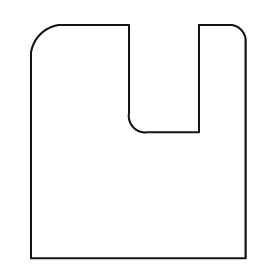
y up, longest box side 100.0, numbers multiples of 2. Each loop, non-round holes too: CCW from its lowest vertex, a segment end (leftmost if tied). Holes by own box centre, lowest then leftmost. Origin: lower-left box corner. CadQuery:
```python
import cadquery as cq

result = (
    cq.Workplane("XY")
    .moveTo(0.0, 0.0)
    .lineTo(92.0, 0.0)
    .lineTo(92.0, 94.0)
    .threePointArc((90.0, 98.0), (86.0, 100.0))
    .lineTo(72.0, 100.0)
    .lineTo(72.0, 54.0)
    .lineTo(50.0, 54.0)
    .threePointArc((44.0, 56.0), (42.0, 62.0))
    .lineTo(42.0, 100.0)
    .lineTo(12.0, 100.0)
    .threePointArc((4.0, 96.0), (0.0, 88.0))
    .close()
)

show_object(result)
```